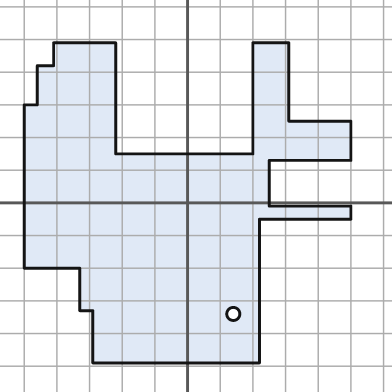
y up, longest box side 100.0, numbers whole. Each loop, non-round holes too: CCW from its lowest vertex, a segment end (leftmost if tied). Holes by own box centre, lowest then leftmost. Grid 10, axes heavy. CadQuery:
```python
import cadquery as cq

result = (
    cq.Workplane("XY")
    .moveTo(-29.0, -49.0)
    .lineTo(22.0, -49.0)
    .lineTo(22.0, -5.0)
    .lineTo(50.0, -5.0)
    .lineTo(50.0, -1.0)
    .lineTo(25.0, -1.0)
    .lineTo(25.0, 13.0)
    .lineTo(50.0, 13.0)
    .lineTo(50.0, 25.0)
    .lineTo(31.0, 25.0)
    .lineTo(31.0, 49.0)
    .lineTo(20.0, 49.0)
    .lineTo(20.0, 15.0)
    .lineTo(-22.0, 15.0)
    .lineTo(-22.0, 49.0)
    .lineTo(-41.0, 49.0)
    .lineTo(-41.0, 42.0)
    .lineTo(-46.0, 42.0)
    .lineTo(-46.0, 30.0)
    .lineTo(-50.0, 30.0)
    .lineTo(-50.0, -20.0)
    .lineTo(-33.0, -20.0)
    .lineTo(-33.0, -33.0)
    .lineTo(-29.0, -33.0)
    .close()
    .moveTo(14.0, -34.0)
    .circle(2.0)
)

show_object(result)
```